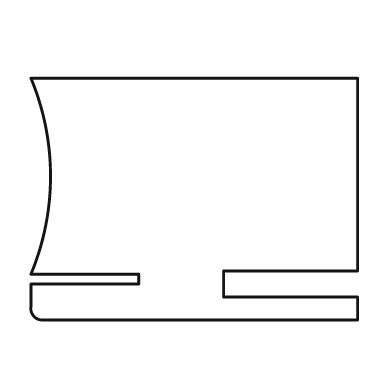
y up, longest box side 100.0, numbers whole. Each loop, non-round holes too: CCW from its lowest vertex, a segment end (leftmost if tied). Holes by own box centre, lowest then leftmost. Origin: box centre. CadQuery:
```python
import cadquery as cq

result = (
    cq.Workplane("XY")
    .moveTo(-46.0, -37.0)
    .lineTo(50.0, -37.0)
    .lineTo(50.0, -30.0)
    .lineTo(9.0, -30.0)
    .lineTo(9.0, -22.0)
    .lineTo(50.0, -22.0)
    .lineTo(50.0, 37.0)
    .lineTo(-50.0, 37.0)
    .threePointArc((-44.0, 7.0), (-50.0, -23.0))
    .lineTo(-17.0, -23.0)
    .lineTo(-17.0, -26.0)
    .lineTo(-50.0, -26.0)
    .lineTo(-50.0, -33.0)
    .threePointArc((-49.0, -36.0), (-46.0, -37.0))
    .close()
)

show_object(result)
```